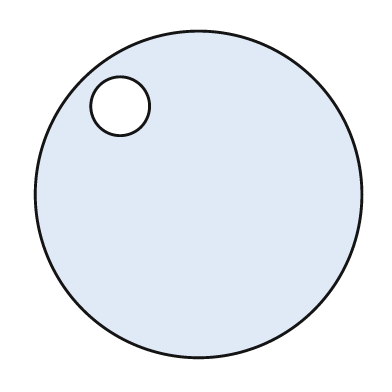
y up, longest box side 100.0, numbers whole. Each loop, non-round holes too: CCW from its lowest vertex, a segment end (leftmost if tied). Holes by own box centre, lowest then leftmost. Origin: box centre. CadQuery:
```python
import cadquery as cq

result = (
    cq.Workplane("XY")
    .moveTo(0.0, 0.0)
    .circle(50.0)
    .moveTo(-24.0, 27.0)
    .circle(9.0)
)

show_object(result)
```